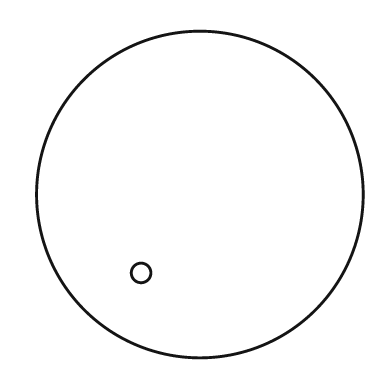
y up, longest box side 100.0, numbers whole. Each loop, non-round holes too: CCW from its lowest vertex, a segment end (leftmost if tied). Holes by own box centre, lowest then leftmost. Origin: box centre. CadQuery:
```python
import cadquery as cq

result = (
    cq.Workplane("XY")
    .moveTo(0.0, 0.0)
    .circle(50.0)
    .moveTo(-18.0, -24.0)
    .circle(3.0)
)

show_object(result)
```